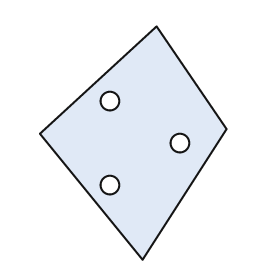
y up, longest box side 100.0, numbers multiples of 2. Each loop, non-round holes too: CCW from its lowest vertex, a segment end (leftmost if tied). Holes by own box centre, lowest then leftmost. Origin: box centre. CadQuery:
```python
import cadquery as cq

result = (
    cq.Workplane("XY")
    .moveTo(4.0, -50.0)
    .lineTo(40.0, 6.0)
    .lineTo(10.0, 50.0)
    .lineTo(-40.0, 4.0)
    .close()
    .moveTo(-10.0, -18.0)
    .circle(4.0)
    .moveTo(20.0, 0.0)
    .circle(4.0)
    .moveTo(-10.0, 18.0)
    .circle(4.0)
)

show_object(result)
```